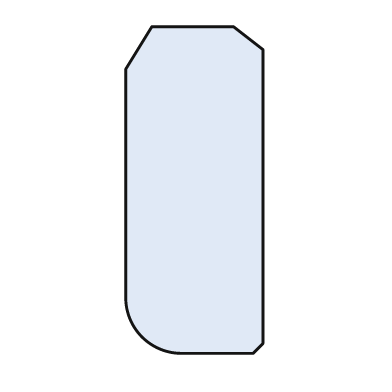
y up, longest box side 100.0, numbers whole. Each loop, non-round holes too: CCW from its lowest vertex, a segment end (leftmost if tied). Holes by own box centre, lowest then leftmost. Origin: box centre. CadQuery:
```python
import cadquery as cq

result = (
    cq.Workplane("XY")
    .moveTo(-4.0, -50.0)
    .lineTo(18.0, -50.0)
    .lineTo(21.0, -47.0)
    .lineTo(21.0, 43.0)
    .lineTo(12.0, 50.0)
    .lineTo(-13.0, 50.0)
    .lineTo(-21.0, 37.0)
    .lineTo(-21.0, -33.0)
    .threePointArc((-16.0, -45.0), (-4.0, -50.0))
    .close()
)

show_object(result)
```